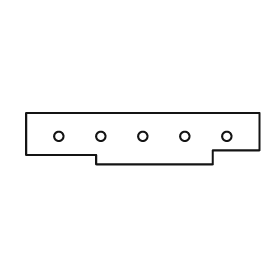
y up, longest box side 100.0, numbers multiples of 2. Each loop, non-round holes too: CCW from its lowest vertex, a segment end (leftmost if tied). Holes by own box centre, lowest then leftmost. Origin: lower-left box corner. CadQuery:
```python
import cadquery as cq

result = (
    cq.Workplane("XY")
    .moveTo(30.0, 0.0)
    .lineTo(80.0, 0.0)
    .lineTo(80.0, 6.0)
    .lineTo(100.0, 6.0)
    .lineTo(100.0, 22.0)
    .lineTo(0.0, 22.0)
    .lineTo(0.0, 4.0)
    .lineTo(30.0, 4.0)
    .close()
    .moveTo(14.0, 12.0)
    .circle(2.0)
    .moveTo(32.0, 12.0)
    .circle(2.0)
    .moveTo(50.0, 12.0)
    .circle(2.0)
    .moveTo(68.0, 12.0)
    .circle(2.0)
    .moveTo(86.0, 12.0)
    .circle(2.0)
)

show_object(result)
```